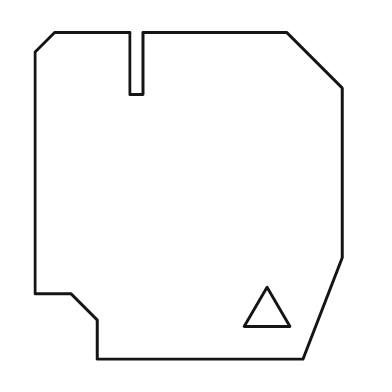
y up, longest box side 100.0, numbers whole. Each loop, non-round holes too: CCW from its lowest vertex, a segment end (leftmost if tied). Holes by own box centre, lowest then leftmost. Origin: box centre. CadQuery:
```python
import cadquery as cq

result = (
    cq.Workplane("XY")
    .moveTo(-28.0, -50.0)
    .lineTo(35.0, -50.0)
    .lineTo(47.0, -19.0)
    .lineTo(47.0, 33.0)
    .lineTo(30.0, 50.0)
    .lineTo(-14.0, 50.0)
    .lineTo(-14.0, 31.0)
    .lineTo(-18.0, 31.0)
    .lineTo(-18.0, 50.0)
    .lineTo(-41.0, 50.0)
    .lineTo(-47.0, 44.0)
    .lineTo(-47.0, -30.0)
    .lineTo(-36.0, -30.0)
    .lineTo(-28.0, -38.0)
    .close()
    .moveTo(17.0, -40.0)
    .lineTo(31.0, -40.0)
    .lineTo(24.0, -28.0)
    .close()
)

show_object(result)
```